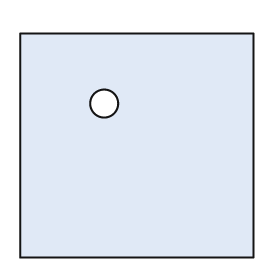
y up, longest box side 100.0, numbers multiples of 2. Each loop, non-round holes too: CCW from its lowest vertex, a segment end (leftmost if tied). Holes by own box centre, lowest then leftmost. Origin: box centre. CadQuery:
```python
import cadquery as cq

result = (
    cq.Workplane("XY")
    .moveTo(-50.0, -48.0)
    .lineTo(50.0, -48.0)
    .lineTo(50.0, 48.0)
    .lineTo(-50.0, 48.0)
    .close()
    .moveTo(-14.0, 18.0)
    .circle(6.0)
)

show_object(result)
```